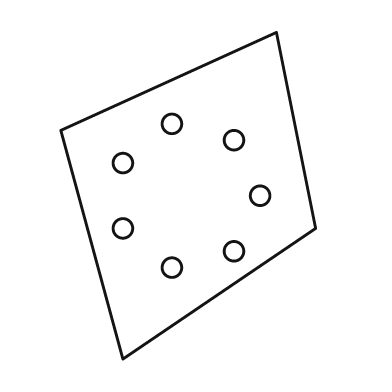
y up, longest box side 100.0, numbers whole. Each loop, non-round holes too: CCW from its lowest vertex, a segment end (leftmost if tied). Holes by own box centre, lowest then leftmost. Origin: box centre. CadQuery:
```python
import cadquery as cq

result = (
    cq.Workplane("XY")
    .moveTo(-20.0, -50.0)
    .lineTo(39.0, -10.0)
    .lineTo(27.0, 50.0)
    .lineTo(-39.0, 20.0)
    .close()
    .moveTo(-5.0, -22.0)
    .circle(3.0)
    .moveTo(14.0, -17.0)
    .circle(3.0)
    .moveTo(-20.0, -10.0)
    .circle(3.0)
    .moveTo(22.0, 0.0)
    .circle(3.0)
    .moveTo(-20.0, 10.0)
    .circle(3.0)
    .moveTo(14.0, 17.0)
    .circle(3.0)
    .moveTo(-5.0, 22.0)
    .circle(3.0)
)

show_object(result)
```